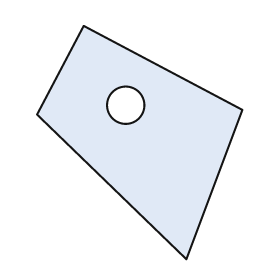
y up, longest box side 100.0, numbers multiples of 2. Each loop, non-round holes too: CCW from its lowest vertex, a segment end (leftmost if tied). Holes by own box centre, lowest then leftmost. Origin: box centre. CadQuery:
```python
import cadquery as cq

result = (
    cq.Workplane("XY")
    .moveTo(20.0, -50.0)
    .lineTo(44.0, 14.0)
    .lineTo(-24.0, 50.0)
    .lineTo(-44.0, 12.0)
    .close()
    .moveTo(-6.0, 16.0)
    .circle(8.0)
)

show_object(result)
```